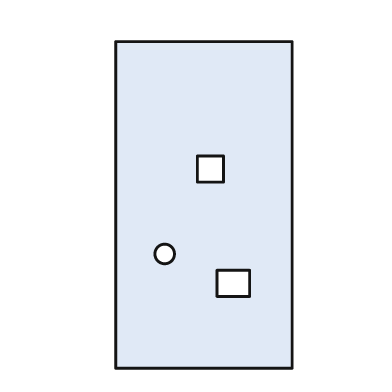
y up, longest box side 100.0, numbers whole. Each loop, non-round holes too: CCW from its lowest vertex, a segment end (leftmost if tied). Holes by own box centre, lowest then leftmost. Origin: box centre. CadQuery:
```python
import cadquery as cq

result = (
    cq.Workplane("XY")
    .moveTo(-27.0, -50.0)
    .lineTo(27.0, -50.0)
    .lineTo(27.0, 50.0)
    .lineTo(-27.0, 50.0)
    .close()
    .moveTo(4.0, -28.0)
    .lineTo(14.0, -28.0)
    .lineTo(14.0, -20.0)
    .lineTo(4.0, -20.0)
    .close()
    .moveTo(-12.0, -15.0)
    .circle(3.0)
    .moveTo(-2.0, 7.0)
    .lineTo(6.0, 7.0)
    .lineTo(6.0, 15.0)
    .lineTo(-2.0, 15.0)
    .close()
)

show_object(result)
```